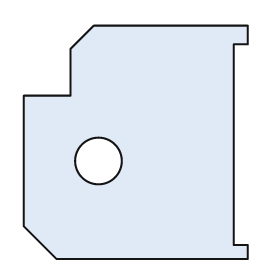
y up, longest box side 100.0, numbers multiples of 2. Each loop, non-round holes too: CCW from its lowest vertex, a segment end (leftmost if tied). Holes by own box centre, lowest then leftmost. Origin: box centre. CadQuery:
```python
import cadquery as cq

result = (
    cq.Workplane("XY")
    .moveTo(-34.0, -50.0)
    .lineTo(48.0, -50.0)
    .lineTo(48.0, -44.0)
    .lineTo(42.0, -44.0)
    .lineTo(42.0, 42.0)
    .lineTo(48.0, 42.0)
    .lineTo(48.0, 50.0)
    .lineTo(-18.0, 50.0)
    .lineTo(-28.0, 40.0)
    .lineTo(-28.0, 20.0)
    .lineTo(-48.0, 20.0)
    .lineTo(-48.0, -36.0)
    .close()
    .moveTo(-16.0, -8.0)
    .circle(10.0)
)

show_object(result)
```